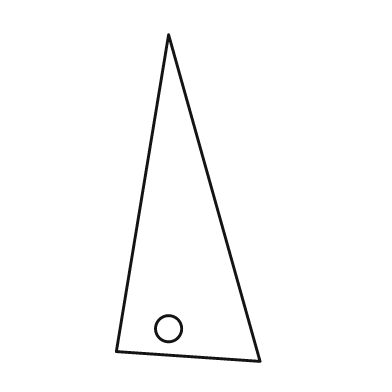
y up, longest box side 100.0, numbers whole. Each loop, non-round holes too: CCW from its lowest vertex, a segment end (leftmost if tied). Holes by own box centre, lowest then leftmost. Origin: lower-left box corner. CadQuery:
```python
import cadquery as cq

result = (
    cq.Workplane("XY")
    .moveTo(44.0, 0.0)
    .lineTo(16.0, 100.0)
    .lineTo(0.0, 3.0)
    .close()
    .moveTo(16.0, 10.0)
    .circle(4.0)
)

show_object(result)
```